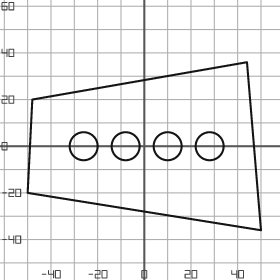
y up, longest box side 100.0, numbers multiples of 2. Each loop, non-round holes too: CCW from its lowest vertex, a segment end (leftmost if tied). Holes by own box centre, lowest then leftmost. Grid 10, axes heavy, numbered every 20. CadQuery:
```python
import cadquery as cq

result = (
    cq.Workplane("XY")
    .moveTo(50.0, -36.0)
    .lineTo(44.0, 36.0)
    .lineTo(-48.0, 20.0)
    .lineTo(-50.0, -20.0)
    .close()
    .moveTo(-26.0, 0.0)
    .circle(6.0)
    .moveTo(-8.0, 0.0)
    .circle(6.0)
    .moveTo(10.0, 0.0)
    .circle(6.0)
    .moveTo(28.0, 0.0)
    .circle(6.0)
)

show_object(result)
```